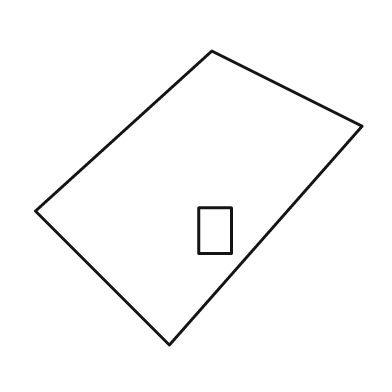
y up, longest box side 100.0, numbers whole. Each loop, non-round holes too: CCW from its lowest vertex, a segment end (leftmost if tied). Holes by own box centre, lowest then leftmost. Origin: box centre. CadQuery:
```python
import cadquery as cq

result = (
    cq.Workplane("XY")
    .moveTo(-9.0, -45.0)
    .lineTo(50.0, 22.0)
    .lineTo(4.0, 45.0)
    .lineTo(-50.0, -4.0)
    .close()
    .moveTo(0.0, -17.0)
    .lineTo(10.0, -17.0)
    .lineTo(10.0, -3.0)
    .lineTo(0.0, -3.0)
    .close()
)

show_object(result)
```